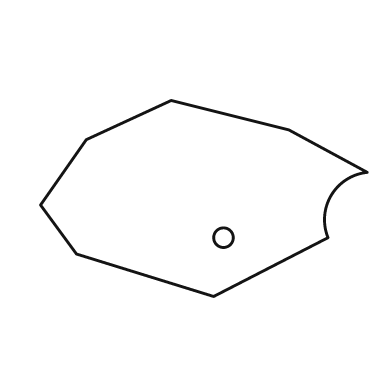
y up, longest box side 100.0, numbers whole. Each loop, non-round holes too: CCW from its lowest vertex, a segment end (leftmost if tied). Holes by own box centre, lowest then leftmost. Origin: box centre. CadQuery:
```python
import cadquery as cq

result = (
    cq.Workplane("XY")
    .moveTo(3.0, -30.0)
    .lineTo(38.0, -12.0)
    .threePointArc((39.0, 1.0), (50.0, 8.0))
    .lineTo(26.0, 21.0)
    .lineTo(-10.0, 30.0)
    .lineTo(-36.0, 18.0)
    .lineTo(-50.0, -2.0)
    .lineTo(-39.0, -17.0)
    .close()
    .moveTo(6.0, -12.0)
    .circle(3.0)
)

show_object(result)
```